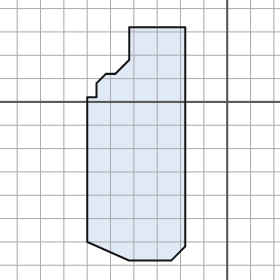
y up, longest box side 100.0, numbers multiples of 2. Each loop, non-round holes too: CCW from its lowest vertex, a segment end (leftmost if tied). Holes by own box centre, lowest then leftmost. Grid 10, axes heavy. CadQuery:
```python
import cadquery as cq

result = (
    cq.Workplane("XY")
    .moveTo(-42.0, -68.0)
    .lineTo(-24.0, -68.0)
    .lineTo(-18.0, -62.0)
    .lineTo(-18.0, 32.0)
    .lineTo(-42.0, 32.0)
    .lineTo(-42.0, 18.0)
    .lineTo(-48.0, 12.0)
    .lineTo(-52.0, 12.0)
    .lineTo(-56.0, 8.0)
    .lineTo(-56.0, 2.0)
    .lineTo(-60.0, 2.0)
    .lineTo(-60.0, -60.0)
    .close()
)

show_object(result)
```